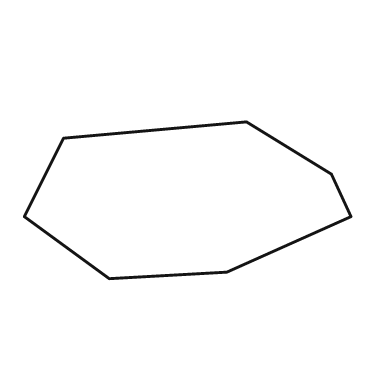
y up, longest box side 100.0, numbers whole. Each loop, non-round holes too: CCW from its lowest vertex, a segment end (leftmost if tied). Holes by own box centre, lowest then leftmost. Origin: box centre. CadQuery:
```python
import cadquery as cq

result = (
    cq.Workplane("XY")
    .moveTo(-24.0, -24.0)
    .lineTo(12.0, -22.0)
    .lineTo(50.0, -5.0)
    .lineTo(44.0, 8.0)
    .lineTo(18.0, 24.0)
    .lineTo(-38.0, 19.0)
    .lineTo(-50.0, -5.0)
    .close()
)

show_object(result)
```